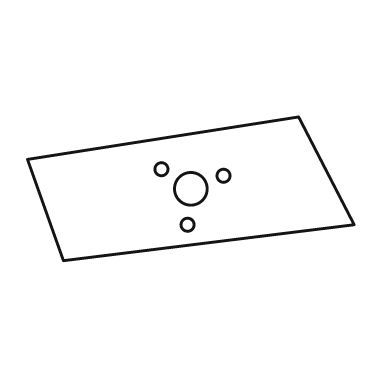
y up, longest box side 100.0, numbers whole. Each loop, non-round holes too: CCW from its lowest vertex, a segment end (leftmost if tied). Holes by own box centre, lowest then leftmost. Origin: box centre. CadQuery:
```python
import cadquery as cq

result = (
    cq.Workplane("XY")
    .moveTo(-39.0, -22.0)
    .lineTo(50.0, -11.0)
    .lineTo(33.0, 22.0)
    .lineTo(-50.0, 9.0)
    .close()
    .moveTo(-1.0, -11.0)
    .circle(2.0)
    .moveTo(0.0, 0.0)
    .circle(5.0)
    .moveTo(10.0, 4.0)
    .circle(2.0)
    .moveTo(-9.0, 6.0)
    .circle(2.0)
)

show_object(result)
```